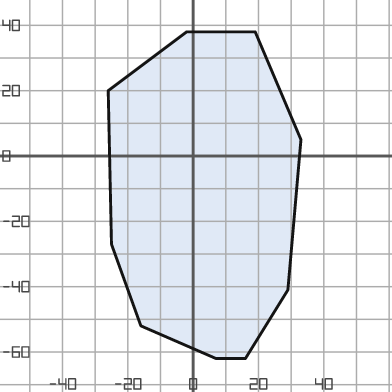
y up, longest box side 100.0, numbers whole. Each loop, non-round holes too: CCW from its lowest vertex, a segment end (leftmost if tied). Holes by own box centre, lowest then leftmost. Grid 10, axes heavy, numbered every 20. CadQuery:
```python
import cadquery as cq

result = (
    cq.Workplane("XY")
    .moveTo(7.0, -62.0)
    .lineTo(16.0, -62.0)
    .lineTo(29.0, -41.0)
    .lineTo(33.0, 5.0)
    .lineTo(19.0, 38.0)
    .lineTo(-2.0, 38.0)
    .lineTo(-26.0, 20.0)
    .lineTo(-25.0, -27.0)
    .lineTo(-16.0, -52.0)
    .close()
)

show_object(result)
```